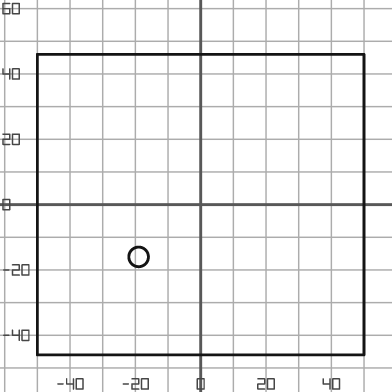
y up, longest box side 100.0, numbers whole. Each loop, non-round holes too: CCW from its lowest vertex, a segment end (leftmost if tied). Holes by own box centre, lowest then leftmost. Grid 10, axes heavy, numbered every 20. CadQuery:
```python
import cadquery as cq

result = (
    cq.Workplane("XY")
    .moveTo(-50.0, -46.0)
    .lineTo(50.0, -46.0)
    .lineTo(50.0, 46.0)
    .lineTo(-50.0, 46.0)
    .close()
    .moveTo(-19.0, -16.0)
    .circle(3.0)
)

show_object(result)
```